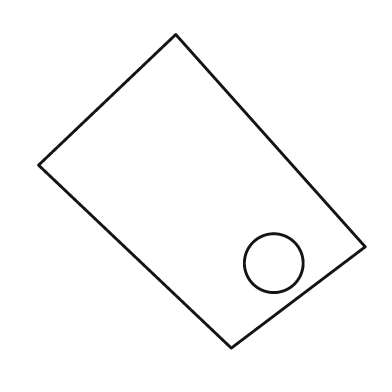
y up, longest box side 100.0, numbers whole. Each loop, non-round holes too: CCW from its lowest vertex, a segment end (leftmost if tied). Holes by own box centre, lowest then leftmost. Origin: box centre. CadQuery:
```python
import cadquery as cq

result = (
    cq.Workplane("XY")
    .moveTo(9.0, -48.0)
    .lineTo(50.0, -17.0)
    .lineTo(-8.0, 48.0)
    .lineTo(-50.0, 8.0)
    .close()
    .moveTo(22.0, -22.0)
    .circle(9.0)
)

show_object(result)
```